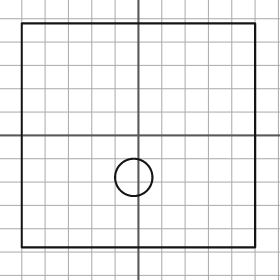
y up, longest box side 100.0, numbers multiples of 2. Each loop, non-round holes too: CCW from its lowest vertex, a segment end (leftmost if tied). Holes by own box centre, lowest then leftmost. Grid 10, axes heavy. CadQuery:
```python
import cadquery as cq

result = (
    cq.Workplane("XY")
    .moveTo(-50.0, -48.0)
    .lineTo(50.0, -48.0)
    .lineTo(50.0, 48.0)
    .lineTo(-50.0, 48.0)
    .close()
    .moveTo(-2.0, -18.0)
    .circle(8.0)
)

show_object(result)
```